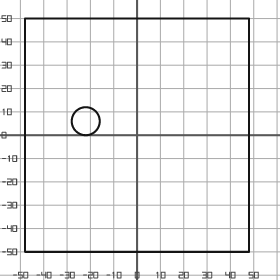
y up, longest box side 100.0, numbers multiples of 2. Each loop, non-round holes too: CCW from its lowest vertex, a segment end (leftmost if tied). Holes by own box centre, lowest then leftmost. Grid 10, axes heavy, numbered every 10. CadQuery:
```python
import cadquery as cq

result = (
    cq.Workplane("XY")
    .moveTo(-48.0, -50.0)
    .lineTo(48.0, -50.0)
    .lineTo(48.0, 50.0)
    .lineTo(-48.0, 50.0)
    .close()
    .moveTo(-22.0, 6.0)
    .circle(6.0)
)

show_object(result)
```